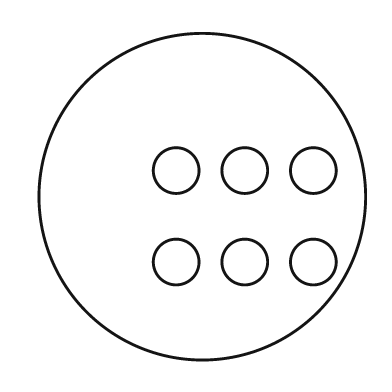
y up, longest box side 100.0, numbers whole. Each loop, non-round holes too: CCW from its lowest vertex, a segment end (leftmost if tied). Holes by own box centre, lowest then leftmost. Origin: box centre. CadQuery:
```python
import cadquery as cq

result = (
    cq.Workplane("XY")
    .moveTo(0.0, 0.0)
    .circle(50.0)
    .moveTo(-8.0, -20.0)
    .circle(7.0)
    .moveTo(13.0, -20.0)
    .circle(7.0)
    .moveTo(34.0, -20.0)
    .circle(7.0)
    .moveTo(-8.0, 8.0)
    .circle(7.0)
    .moveTo(13.0, 8.0)
    .circle(7.0)
    .moveTo(34.0, 8.0)
    .circle(7.0)
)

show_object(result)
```